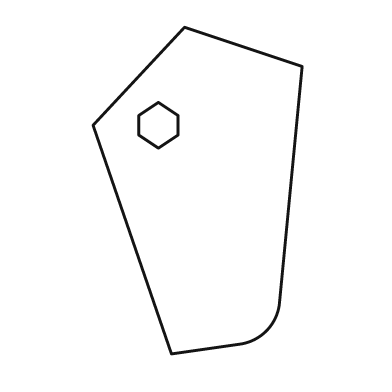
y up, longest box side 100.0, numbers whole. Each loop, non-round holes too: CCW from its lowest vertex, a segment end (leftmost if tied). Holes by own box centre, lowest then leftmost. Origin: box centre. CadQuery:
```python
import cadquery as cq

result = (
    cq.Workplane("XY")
    .moveTo(-8.0, -50.0)
    .lineTo(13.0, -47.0)
    .threePointArc((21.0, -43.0), (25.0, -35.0))
    .lineTo(32.0, 38.0)
    .lineTo(-4.0, 50.0)
    .lineTo(-32.0, 20.0)
    .close()
    .moveTo(-12.0, 13.0)
    .lineTo(-6.0, 17.0)
    .lineTo(-6.0, 23.0)
    .lineTo(-12.0, 27.0)
    .lineTo(-18.0, 23.0)
    .lineTo(-18.0, 17.0)
    .close()
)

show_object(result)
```